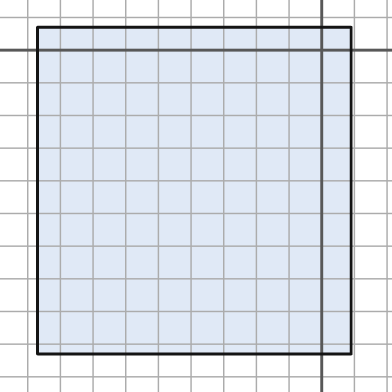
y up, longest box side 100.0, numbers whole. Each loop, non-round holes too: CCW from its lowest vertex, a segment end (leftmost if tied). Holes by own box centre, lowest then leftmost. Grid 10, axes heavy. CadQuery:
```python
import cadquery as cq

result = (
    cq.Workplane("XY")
    .moveTo(-87.0, -93.0)
    .lineTo(9.0, -93.0)
    .lineTo(9.0, 7.0)
    .lineTo(-87.0, 7.0)
    .close()
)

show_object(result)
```